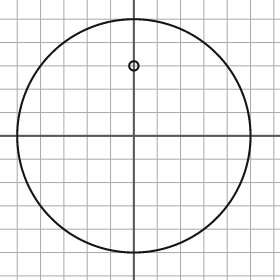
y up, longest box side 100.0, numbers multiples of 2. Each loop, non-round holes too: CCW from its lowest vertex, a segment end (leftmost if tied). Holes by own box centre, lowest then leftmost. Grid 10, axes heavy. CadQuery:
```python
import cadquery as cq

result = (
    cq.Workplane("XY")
    .moveTo(0.0, 0.0)
    .circle(50.0)
    .moveTo(0.0, 30.0)
    .circle(2.0)
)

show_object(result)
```